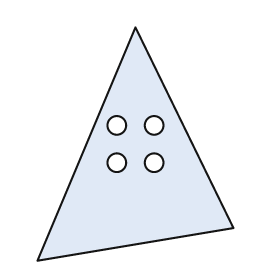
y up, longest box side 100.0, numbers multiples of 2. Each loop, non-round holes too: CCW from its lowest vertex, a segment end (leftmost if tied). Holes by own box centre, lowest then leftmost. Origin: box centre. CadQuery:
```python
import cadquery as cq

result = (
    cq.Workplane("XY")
    .moveTo(-42.0, -50.0)
    .lineTo(42.0, -36.0)
    .lineTo(0.0, 50.0)
    .close()
    .moveTo(-8.0, -8.0)
    .circle(4.0)
    .moveTo(8.0, -8.0)
    .circle(4.0)
    .moveTo(-8.0, 8.0)
    .circle(4.0)
    .moveTo(8.0, 8.0)
    .circle(4.0)
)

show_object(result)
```